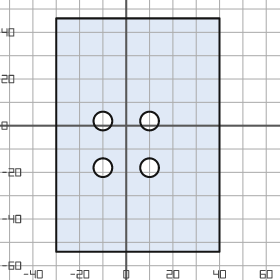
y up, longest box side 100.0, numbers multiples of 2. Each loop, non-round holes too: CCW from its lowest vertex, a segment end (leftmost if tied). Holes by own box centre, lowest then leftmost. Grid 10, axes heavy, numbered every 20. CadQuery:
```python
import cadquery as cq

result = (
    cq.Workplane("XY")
    .moveTo(-30.0, -54.0)
    .lineTo(40.0, -54.0)
    .lineTo(40.0, 46.0)
    .lineTo(-30.0, 46.0)
    .close()
    .moveTo(-10.0, -18.0)
    .circle(4.0)
    .moveTo(10.0, -18.0)
    .circle(4.0)
    .moveTo(-10.0, 2.0)
    .circle(4.0)
    .moveTo(10.0, 2.0)
    .circle(4.0)
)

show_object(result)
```